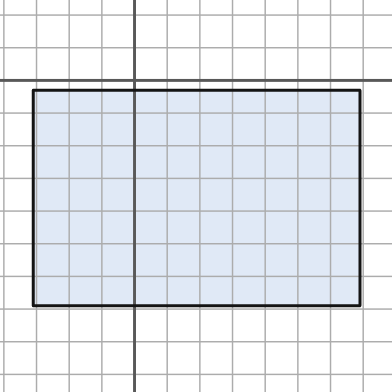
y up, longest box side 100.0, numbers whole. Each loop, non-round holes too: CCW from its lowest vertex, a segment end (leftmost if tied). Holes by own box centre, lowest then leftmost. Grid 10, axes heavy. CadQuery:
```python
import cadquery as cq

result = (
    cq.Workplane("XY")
    .moveTo(-31.0, -69.0)
    .lineTo(69.0, -69.0)
    .lineTo(69.0, -3.0)
    .lineTo(-31.0, -3.0)
    .close()
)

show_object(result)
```